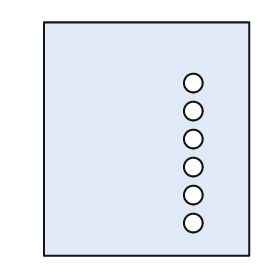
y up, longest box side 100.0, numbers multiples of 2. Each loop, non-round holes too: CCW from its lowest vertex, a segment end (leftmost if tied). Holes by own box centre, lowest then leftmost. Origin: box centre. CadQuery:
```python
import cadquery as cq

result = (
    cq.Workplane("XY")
    .moveTo(-44.0, -50.0)
    .lineTo(44.0, -50.0)
    .lineTo(44.0, 50.0)
    .lineTo(-44.0, 50.0)
    .close()
    .moveTo(20.0, -36.0)
    .circle(4.0)
    .moveTo(20.0, -24.0)
    .circle(4.0)
    .moveTo(20.0, -12.0)
    .circle(4.0)
    .moveTo(20.0, 0.0)
    .circle(4.0)
    .moveTo(20.0, 12.0)
    .circle(4.0)
    .moveTo(20.0, 24.0)
    .circle(4.0)
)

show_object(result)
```